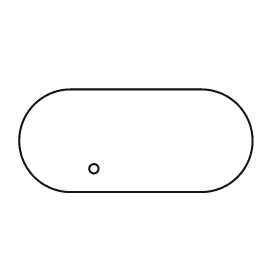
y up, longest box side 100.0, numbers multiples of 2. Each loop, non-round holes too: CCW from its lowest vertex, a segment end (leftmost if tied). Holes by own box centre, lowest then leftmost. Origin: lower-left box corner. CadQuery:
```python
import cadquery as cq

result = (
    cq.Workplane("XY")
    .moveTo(22.0, 0.0)
    .lineTo(78.0, 0.0)
    .threePointArc((100.0, 22.0), (78.0, 44.0))
    .lineTo(22.0, 44.0)
    .threePointArc((0.0, 22.0), (22.0, 0.0))
    .close()
    .moveTo(32.0, 10.0)
    .circle(2.0)
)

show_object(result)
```